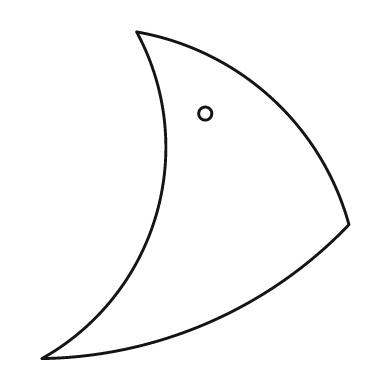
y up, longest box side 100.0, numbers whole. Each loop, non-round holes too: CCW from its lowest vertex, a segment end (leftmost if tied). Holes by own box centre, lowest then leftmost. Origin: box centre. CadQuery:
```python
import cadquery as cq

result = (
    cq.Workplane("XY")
    .moveTo(-47.0, -50.0)
    .threePointArc((4.0, -39.0), (47.0, -9.0))
    .threePointArc((23.0, 30.0), (-18.0, 50.0))
    .threePointArc((-12.0, -6.0), (-47.0, -50.0))
    .close()
    .moveTo(3.0, 25.0)
    .circle(2.0)
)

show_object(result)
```